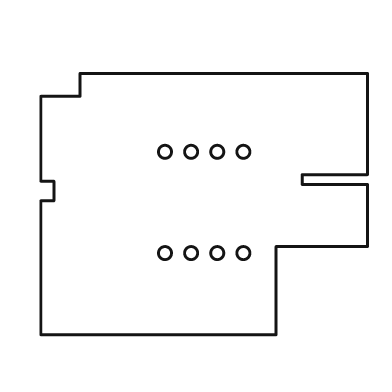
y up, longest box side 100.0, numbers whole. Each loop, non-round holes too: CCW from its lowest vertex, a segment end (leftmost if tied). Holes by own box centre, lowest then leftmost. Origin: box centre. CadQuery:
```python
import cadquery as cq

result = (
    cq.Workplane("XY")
    .moveTo(-50.0, -40.0)
    .lineTo(22.0, -40.0)
    .lineTo(22.0, -13.0)
    .lineTo(50.0, -13.0)
    .lineTo(50.0, 6.0)
    .lineTo(30.0, 6.0)
    .lineTo(30.0, 9.0)
    .lineTo(50.0, 9.0)
    .lineTo(50.0, 40.0)
    .lineTo(-38.0, 40.0)
    .lineTo(-38.0, 33.0)
    .lineTo(-50.0, 33.0)
    .lineTo(-50.0, 7.0)
    .lineTo(-46.0, 7.0)
    .lineTo(-46.0, 1.0)
    .lineTo(-50.0, 1.0)
    .close()
    .moveTo(-12.0, -15.0)
    .circle(2.0)
    .moveTo(-4.0, -15.0)
    .circle(2.0)
    .moveTo(4.0, -15.0)
    .circle(2.0)
    .moveTo(12.0, -15.0)
    .circle(2.0)
    .moveTo(-12.0, 16.0)
    .circle(2.0)
    .moveTo(-4.0, 16.0)
    .circle(2.0)
    .moveTo(4.0, 16.0)
    .circle(2.0)
    .moveTo(12.0, 16.0)
    .circle(2.0)
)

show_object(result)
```